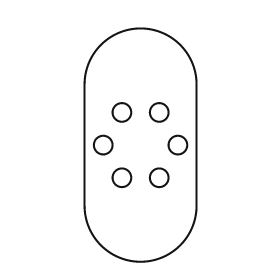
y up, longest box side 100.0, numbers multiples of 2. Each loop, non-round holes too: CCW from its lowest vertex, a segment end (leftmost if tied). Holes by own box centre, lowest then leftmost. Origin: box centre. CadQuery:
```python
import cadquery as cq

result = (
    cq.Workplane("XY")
    .moveTo(-24.0, -26.0)
    .threePointArc((0.0, -50.0), (24.0, -26.0))
    .lineTo(24.0, 26.0)
    .threePointArc((0.0, 50.0), (-24.0, 26.0))
    .close()
    .moveTo(-8.0, -14.0)
    .circle(4.0)
    .moveTo(8.0, -14.0)
    .circle(4.0)
    .moveTo(-16.0, 0.0)
    .circle(4.0)
    .moveTo(16.0, 0.0)
    .circle(4.0)
    .moveTo(-8.0, 14.0)
    .circle(4.0)
    .moveTo(8.0, 14.0)
    .circle(4.0)
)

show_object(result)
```